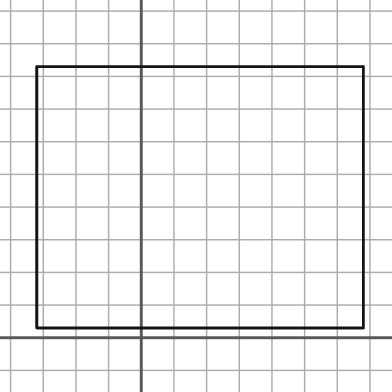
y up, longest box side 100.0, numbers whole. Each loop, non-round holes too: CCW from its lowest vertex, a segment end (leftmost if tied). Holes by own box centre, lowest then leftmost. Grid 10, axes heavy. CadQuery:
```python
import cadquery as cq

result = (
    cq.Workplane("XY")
    .moveTo(-32.0, 3.0)
    .lineTo(68.0, 3.0)
    .lineTo(68.0, 83.0)
    .lineTo(-32.0, 83.0)
    .close()
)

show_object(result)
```